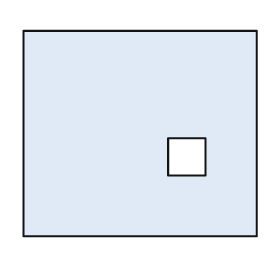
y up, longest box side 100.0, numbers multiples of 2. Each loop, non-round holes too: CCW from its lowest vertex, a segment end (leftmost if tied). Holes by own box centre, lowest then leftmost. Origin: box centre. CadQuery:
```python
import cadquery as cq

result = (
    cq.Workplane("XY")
    .moveTo(-50.0, -44.0)
    .lineTo(50.0, -44.0)
    .lineTo(50.0, 44.0)
    .lineTo(-50.0, 44.0)
    .close()
    .moveTo(12.0, -18.0)
    .lineTo(28.0, -18.0)
    .lineTo(28.0, -2.0)
    .lineTo(12.0, -2.0)
    .close()
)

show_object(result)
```